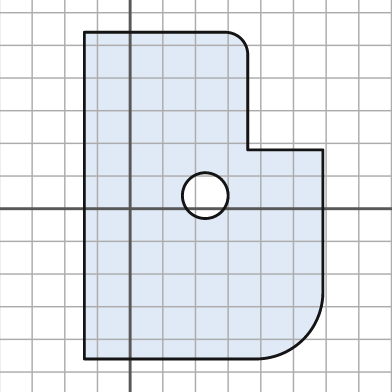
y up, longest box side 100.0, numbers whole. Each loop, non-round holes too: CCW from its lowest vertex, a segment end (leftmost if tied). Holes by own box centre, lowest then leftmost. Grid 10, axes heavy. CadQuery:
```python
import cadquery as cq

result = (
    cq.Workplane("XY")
    .moveTo(-14.0, -46.0)
    .lineTo(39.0, -46.0)
    .threePointArc((53.0, -40.0), (59.0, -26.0))
    .lineTo(59.0, 18.0)
    .lineTo(36.0, 18.0)
    .lineTo(36.0, 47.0)
    .threePointArc((34.0, 52.0), (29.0, 54.0))
    .lineTo(-14.0, 54.0)
    .close()
    .moveTo(23.0, 4.0)
    .circle(7.0)
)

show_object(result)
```